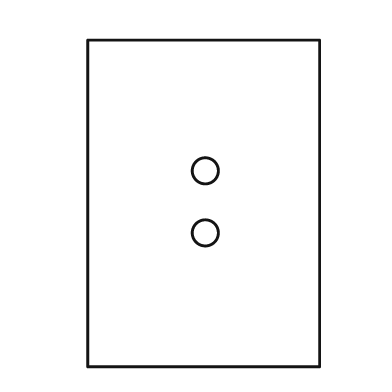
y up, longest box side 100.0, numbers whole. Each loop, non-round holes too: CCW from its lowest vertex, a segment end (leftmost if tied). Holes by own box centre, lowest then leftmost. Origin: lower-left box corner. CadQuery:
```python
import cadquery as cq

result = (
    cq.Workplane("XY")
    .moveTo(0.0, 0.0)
    .lineTo(71.0, 0.0)
    .lineTo(71.0, 100.0)
    .lineTo(0.0, 100.0)
    .close()
    .moveTo(36.0, 41.0)
    .circle(4.0)
    .moveTo(36.0, 60.0)
    .circle(4.0)
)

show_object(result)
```